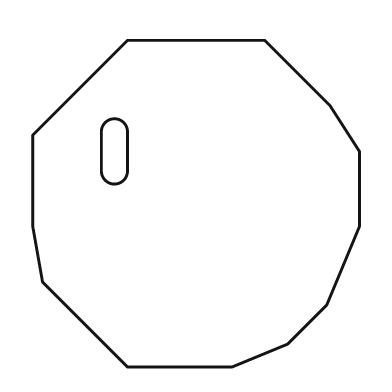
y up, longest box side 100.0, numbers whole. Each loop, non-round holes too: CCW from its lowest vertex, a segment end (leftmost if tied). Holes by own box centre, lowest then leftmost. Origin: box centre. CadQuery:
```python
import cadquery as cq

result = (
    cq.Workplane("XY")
    .moveTo(-21.0, -50.0)
    .lineTo(11.0, -50.0)
    .lineTo(28.0, -43.0)
    .lineTo(40.0, -31.0)
    .lineTo(50.0, -7.0)
    .lineTo(50.0, 16.0)
    .lineTo(41.0, 30.0)
    .lineTo(21.0, 50.0)
    .lineTo(-21.0, 50.0)
    .lineTo(-50.0, 21.0)
    .lineTo(-50.0, -7.0)
    .lineTo(-47.0, -24.0)
    .close()
    .moveTo(-29.0, 10.0)
    .threePointArc((-25.0, 6.0), (-21.0, 10.0))
    .lineTo(-21.0, 22.0)
    .threePointArc((-25.0, 26.0), (-29.0, 22.0))
    .close()
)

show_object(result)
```